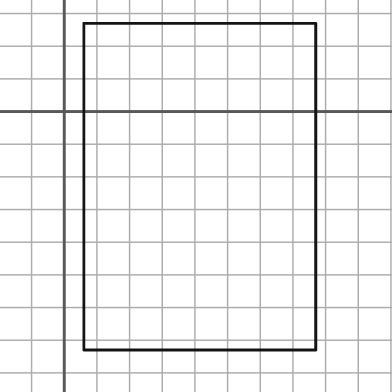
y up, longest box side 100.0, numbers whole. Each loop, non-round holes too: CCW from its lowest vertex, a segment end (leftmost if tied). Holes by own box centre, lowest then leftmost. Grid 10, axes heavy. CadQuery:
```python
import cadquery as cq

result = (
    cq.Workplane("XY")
    .moveTo(6.0, -73.0)
    .lineTo(77.0, -73.0)
    .lineTo(77.0, 27.0)
    .lineTo(6.0, 27.0)
    .close()
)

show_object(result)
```